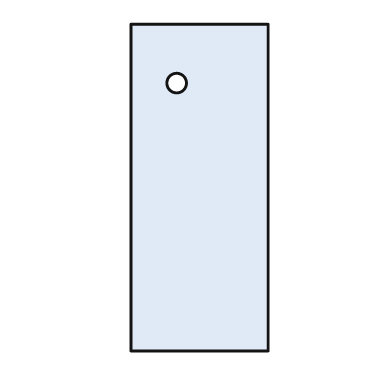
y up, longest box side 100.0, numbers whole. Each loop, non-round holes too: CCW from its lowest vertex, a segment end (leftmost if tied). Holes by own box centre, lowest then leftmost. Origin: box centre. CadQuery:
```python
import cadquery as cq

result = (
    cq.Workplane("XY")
    .moveTo(-21.0, -50.0)
    .lineTo(21.0, -50.0)
    .lineTo(21.0, 50.0)
    .lineTo(-21.0, 50.0)
    .close()
    .moveTo(-7.0, 32.0)
    .circle(3.0)
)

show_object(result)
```